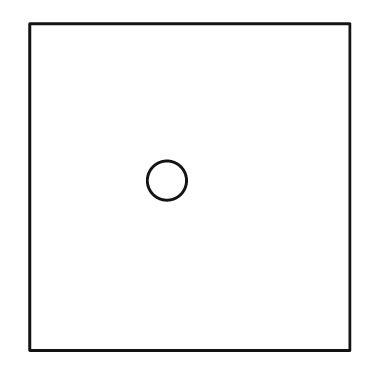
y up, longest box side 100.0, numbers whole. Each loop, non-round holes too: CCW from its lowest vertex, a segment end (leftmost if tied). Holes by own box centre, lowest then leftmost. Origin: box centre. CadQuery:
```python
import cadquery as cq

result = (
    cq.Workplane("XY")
    .moveTo(-49.0, -50.0)
    .lineTo(49.0, -50.0)
    .lineTo(49.0, 50.0)
    .lineTo(-49.0, 50.0)
    .close()
    .moveTo(-7.0, 2.0)
    .circle(6.0)
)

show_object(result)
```